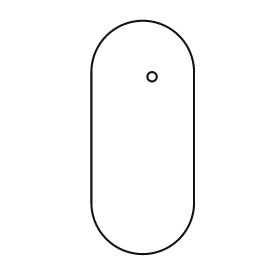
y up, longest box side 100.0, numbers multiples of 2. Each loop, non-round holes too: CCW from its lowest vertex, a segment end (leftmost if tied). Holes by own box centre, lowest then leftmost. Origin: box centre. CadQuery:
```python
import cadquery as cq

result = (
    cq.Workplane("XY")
    .moveTo(-22.0, -28.0)
    .threePointArc((0.0, -50.0), (22.0, -28.0))
    .lineTo(22.0, 28.0)
    .threePointArc((0.0, 50.0), (-22.0, 28.0))
    .close()
    .moveTo(4.0, 26.0)
    .circle(2.0)
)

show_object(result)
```